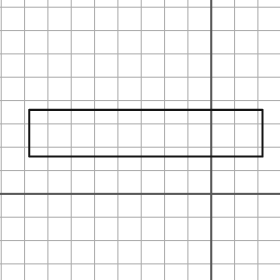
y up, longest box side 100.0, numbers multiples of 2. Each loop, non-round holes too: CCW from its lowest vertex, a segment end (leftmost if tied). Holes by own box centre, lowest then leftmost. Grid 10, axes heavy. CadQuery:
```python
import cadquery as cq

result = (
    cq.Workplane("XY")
    .moveTo(-78.0, 16.0)
    .lineTo(22.0, 16.0)
    .lineTo(22.0, 36.0)
    .lineTo(-78.0, 36.0)
    .close()
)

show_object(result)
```